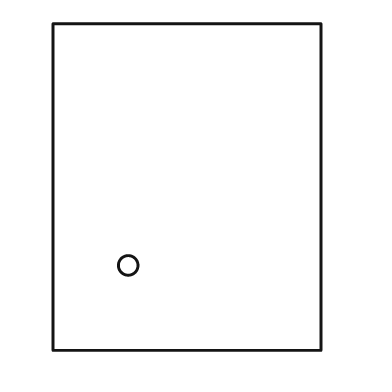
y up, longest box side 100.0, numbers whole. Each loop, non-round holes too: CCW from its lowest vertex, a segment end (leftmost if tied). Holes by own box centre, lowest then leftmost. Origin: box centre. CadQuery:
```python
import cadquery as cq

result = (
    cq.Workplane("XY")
    .moveTo(-41.0, -50.0)
    .lineTo(41.0, -50.0)
    .lineTo(41.0, 50.0)
    .lineTo(-41.0, 50.0)
    .close()
    .moveTo(-18.0, -24.0)
    .circle(3.0)
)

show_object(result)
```